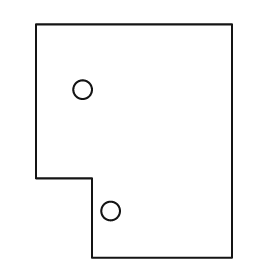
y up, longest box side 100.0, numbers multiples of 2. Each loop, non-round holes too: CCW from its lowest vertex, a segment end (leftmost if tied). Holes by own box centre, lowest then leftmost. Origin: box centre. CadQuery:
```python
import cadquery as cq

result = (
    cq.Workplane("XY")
    .moveTo(-18.0, -50.0)
    .lineTo(42.0, -50.0)
    .lineTo(42.0, 50.0)
    .lineTo(-42.0, 50.0)
    .lineTo(-42.0, -16.0)
    .lineTo(-18.0, -16.0)
    .close()
    .moveTo(-10.0, -30.0)
    .circle(4.0)
    .moveTo(-22.0, 22.0)
    .circle(4.0)
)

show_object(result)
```